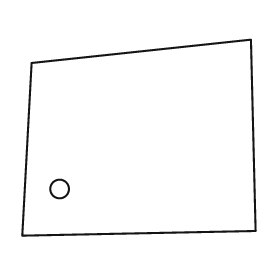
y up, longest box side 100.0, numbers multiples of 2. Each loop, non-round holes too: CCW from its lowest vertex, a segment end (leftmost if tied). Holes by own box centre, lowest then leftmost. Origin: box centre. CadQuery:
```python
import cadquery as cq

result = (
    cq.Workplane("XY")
    .moveTo(-50.0, -42.0)
    .lineTo(50.0, -40.0)
    .lineTo(48.0, 42.0)
    .lineTo(-46.0, 32.0)
    .close()
    .moveTo(-34.0, -22.0)
    .circle(4.0)
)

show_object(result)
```